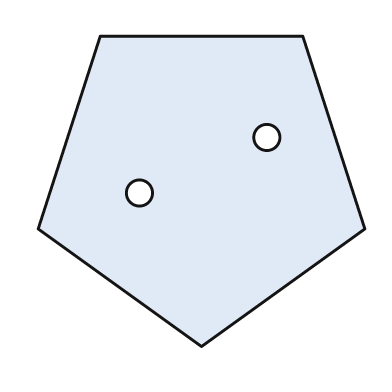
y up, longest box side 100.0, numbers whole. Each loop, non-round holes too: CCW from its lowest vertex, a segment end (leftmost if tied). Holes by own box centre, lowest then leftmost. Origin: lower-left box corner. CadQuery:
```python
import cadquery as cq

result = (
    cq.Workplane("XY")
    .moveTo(50.0, 0.0)
    .lineTo(100.0, 36.0)
    .lineTo(81.0, 95.0)
    .lineTo(19.0, 95.0)
    .lineTo(0.0, 36.0)
    .close()
    .moveTo(31.0, 47.0)
    .circle(4.0)
    .moveTo(70.0, 64.0)
    .circle(4.0)
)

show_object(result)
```